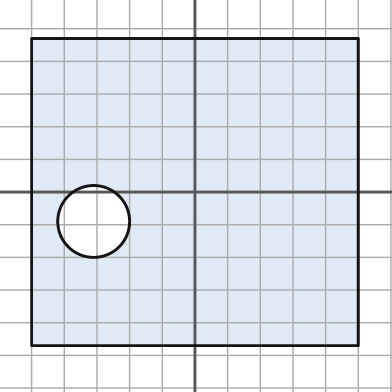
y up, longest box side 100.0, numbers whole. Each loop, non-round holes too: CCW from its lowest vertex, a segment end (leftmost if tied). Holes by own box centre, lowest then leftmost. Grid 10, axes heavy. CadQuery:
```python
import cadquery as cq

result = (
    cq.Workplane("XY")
    .moveTo(-50.0, -47.0)
    .lineTo(50.0, -47.0)
    .lineTo(50.0, 47.0)
    .lineTo(-50.0, 47.0)
    .close()
    .moveTo(-31.0, -9.0)
    .circle(11.0)
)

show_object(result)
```